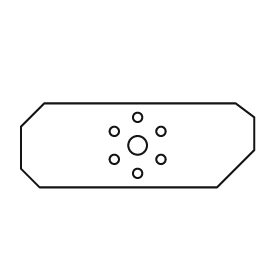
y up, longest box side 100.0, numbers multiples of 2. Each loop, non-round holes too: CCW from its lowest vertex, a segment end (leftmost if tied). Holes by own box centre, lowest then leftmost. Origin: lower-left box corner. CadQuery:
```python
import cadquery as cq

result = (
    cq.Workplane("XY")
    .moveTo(8.0, 0.0)
    .lineTo(84.0, 0.0)
    .lineTo(100.0, 16.0)
    .lineTo(100.0, 30.0)
    .lineTo(92.0, 36.0)
    .lineTo(10.0, 36.0)
    .lineTo(0.0, 26.0)
    .lineTo(0.0, 8.0)
    .close()
    .moveTo(50.0, 6.0)
    .circle(2.0)
    .moveTo(40.0, 12.0)
    .circle(2.0)
    .moveTo(60.0, 12.0)
    .circle(2.0)
    .moveTo(50.0, 18.0)
    .circle(4.0)
    .moveTo(40.0, 24.0)
    .circle(2.0)
    .moveTo(60.0, 24.0)
    .circle(2.0)
    .moveTo(50.0, 30.0)
    .circle(2.0)
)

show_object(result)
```